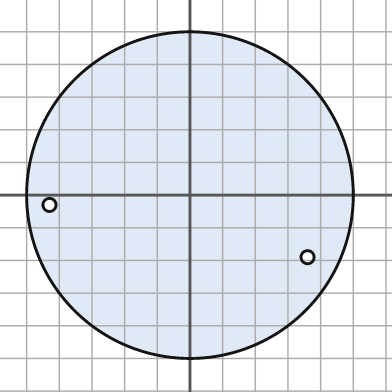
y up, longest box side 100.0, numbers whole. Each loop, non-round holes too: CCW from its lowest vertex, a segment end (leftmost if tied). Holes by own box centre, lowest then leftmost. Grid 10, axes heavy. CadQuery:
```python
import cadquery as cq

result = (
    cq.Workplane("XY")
    .moveTo(0.0, 0.0)
    .circle(50.0)
    .moveTo(36.0, -19.0)
    .circle(2.0)
    .moveTo(-43.0, -3.0)
    .circle(2.0)
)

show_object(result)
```